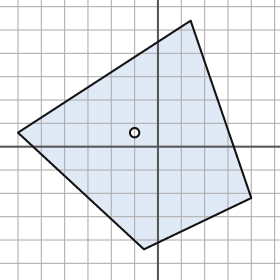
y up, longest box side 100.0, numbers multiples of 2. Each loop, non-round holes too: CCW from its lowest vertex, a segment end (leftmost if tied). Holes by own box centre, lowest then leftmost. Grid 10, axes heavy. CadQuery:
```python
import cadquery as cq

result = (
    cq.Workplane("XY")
    .moveTo(-6.0, -44.0)
    .lineTo(40.0, -22.0)
    .lineTo(14.0, 54.0)
    .lineTo(-60.0, 6.0)
    .close()
    .moveTo(-10.0, 6.0)
    .circle(2.0)
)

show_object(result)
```